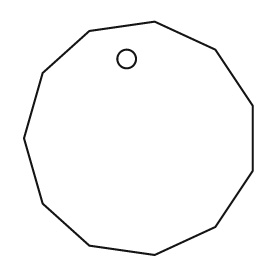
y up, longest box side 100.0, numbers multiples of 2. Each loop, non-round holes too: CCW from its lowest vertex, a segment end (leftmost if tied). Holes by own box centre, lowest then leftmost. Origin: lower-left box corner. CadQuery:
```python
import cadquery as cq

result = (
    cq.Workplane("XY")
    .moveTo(56.0, 0.0)
    .lineTo(82.0, 12.0)
    .lineTo(98.0, 36.0)
    .lineTo(98.0, 64.0)
    .lineTo(82.0, 88.0)
    .lineTo(56.0, 100.0)
    .lineTo(28.0, 96.0)
    .lineTo(8.0, 78.0)
    .lineTo(0.0, 50.0)
    .lineTo(8.0, 22.0)
    .lineTo(28.0, 4.0)
    .close()
    .moveTo(44.0, 84.0)
    .circle(4.0)
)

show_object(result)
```